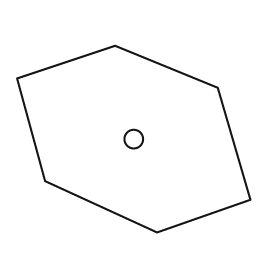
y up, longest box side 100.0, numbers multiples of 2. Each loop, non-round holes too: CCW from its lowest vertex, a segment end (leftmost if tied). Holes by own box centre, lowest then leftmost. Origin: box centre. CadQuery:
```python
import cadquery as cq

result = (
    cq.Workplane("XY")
    .moveTo(10.0, -40.0)
    .lineTo(50.0, -26.0)
    .lineTo(36.0, 22.0)
    .lineTo(-8.0, 40.0)
    .lineTo(-50.0, 26.0)
    .lineTo(-38.0, -18.0)
    .close()
    .moveTo(0.0, 0.0)
    .circle(4.0)
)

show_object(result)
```